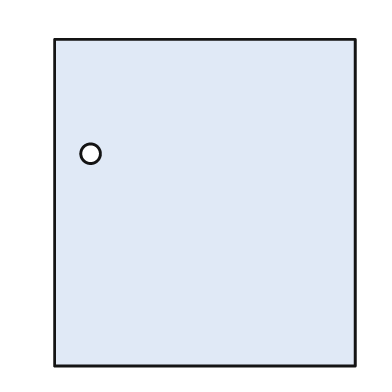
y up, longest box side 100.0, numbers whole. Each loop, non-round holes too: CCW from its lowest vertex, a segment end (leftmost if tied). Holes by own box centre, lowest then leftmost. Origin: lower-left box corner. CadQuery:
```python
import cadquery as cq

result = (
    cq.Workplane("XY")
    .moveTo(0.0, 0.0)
    .lineTo(92.0, 0.0)
    .lineTo(92.0, 100.0)
    .lineTo(0.0, 100.0)
    .close()
    .moveTo(11.0, 65.0)
    .circle(3.0)
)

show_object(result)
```